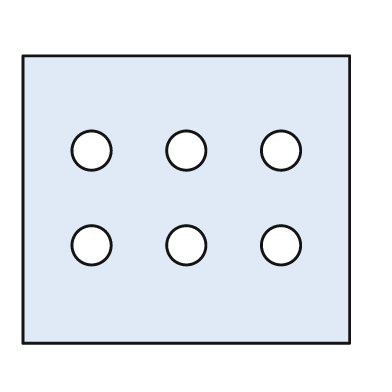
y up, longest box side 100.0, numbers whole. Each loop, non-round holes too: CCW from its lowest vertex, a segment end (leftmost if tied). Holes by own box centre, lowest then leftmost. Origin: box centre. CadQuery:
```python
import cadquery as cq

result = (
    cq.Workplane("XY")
    .moveTo(-50.0, -44.0)
    .lineTo(50.0, -44.0)
    .lineTo(50.0, 44.0)
    .lineTo(-50.0, 44.0)
    .close()
    .moveTo(-29.0, -14.0)
    .circle(6.0)
    .moveTo(0.0, -14.0)
    .circle(6.0)
    .moveTo(29.0, -14.0)
    .circle(6.0)
    .moveTo(-29.0, 15.0)
    .circle(6.0)
    .moveTo(0.0, 15.0)
    .circle(6.0)
    .moveTo(29.0, 15.0)
    .circle(6.0)
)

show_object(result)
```